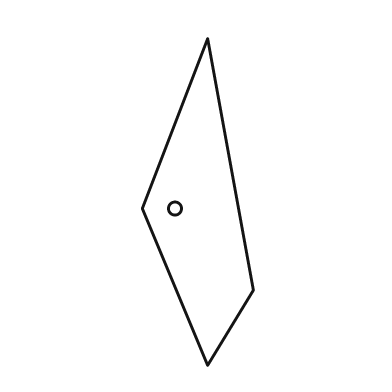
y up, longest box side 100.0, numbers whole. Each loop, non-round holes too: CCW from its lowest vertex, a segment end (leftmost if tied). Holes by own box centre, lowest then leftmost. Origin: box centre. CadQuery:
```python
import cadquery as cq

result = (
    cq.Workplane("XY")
    .moveTo(3.0, -50.0)
    .lineTo(17.0, -27.0)
    .lineTo(3.0, 50.0)
    .lineTo(-17.0, -2.0)
    .close()
    .moveTo(-7.0, -2.0)
    .circle(2.0)
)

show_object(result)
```